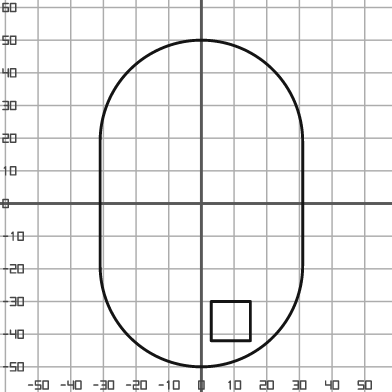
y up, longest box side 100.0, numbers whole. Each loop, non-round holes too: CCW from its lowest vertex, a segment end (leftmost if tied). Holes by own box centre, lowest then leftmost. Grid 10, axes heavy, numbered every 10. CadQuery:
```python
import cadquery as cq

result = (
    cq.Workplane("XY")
    .moveTo(-31.0, -19.0)
    .threePointArc((0.0, -50.0), (31.0, -19.0))
    .lineTo(31.0, 19.0)
    .threePointArc((0.0, 50.0), (-31.0, 19.0))
    .close()
    .moveTo(3.0, -42.0)
    .lineTo(15.0, -42.0)
    .lineTo(15.0, -30.0)
    .lineTo(3.0, -30.0)
    .close()
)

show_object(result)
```